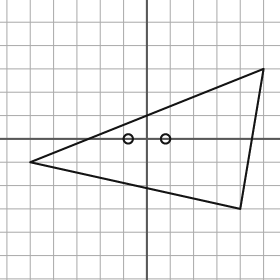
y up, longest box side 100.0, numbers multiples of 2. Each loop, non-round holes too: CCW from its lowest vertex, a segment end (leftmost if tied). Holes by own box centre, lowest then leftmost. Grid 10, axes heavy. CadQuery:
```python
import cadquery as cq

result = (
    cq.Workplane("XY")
    .moveTo(40.0, -30.0)
    .lineTo(50.0, 30.0)
    .lineTo(-50.0, -10.0)
    .close()
    .moveTo(-8.0, 0.0)
    .circle(2.0)
    .moveTo(8.0, 0.0)
    .circle(2.0)
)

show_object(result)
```